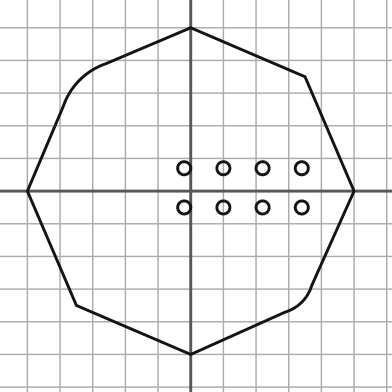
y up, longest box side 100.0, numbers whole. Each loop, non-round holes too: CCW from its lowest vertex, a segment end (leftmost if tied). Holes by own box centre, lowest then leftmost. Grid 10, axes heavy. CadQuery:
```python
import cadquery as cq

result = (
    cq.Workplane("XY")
    .moveTo(0.0, -50.0)
    .lineTo(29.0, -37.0)
    .threePointArc((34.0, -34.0), (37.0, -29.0))
    .lineTo(50.0, 0.0)
    .lineTo(35.0, 35.0)
    .lineTo(0.0, 50.0)
    .lineTo(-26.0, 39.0)
    .threePointArc((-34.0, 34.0), (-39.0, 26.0))
    .lineTo(-50.0, 0.0)
    .lineTo(-35.0, -35.0)
    .close()
    .moveTo(-2.0, -5.0)
    .circle(2.0)
    .moveTo(10.0, -5.0)
    .circle(2.0)
    .moveTo(22.0, -5.0)
    .circle(2.0)
    .moveTo(34.0, -5.0)
    .circle(2.0)
    .moveTo(-2.0, 7.0)
    .circle(2.0)
    .moveTo(10.0, 7.0)
    .circle(2.0)
    .moveTo(22.0, 7.0)
    .circle(2.0)
    .moveTo(34.0, 7.0)
    .circle(2.0)
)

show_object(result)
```